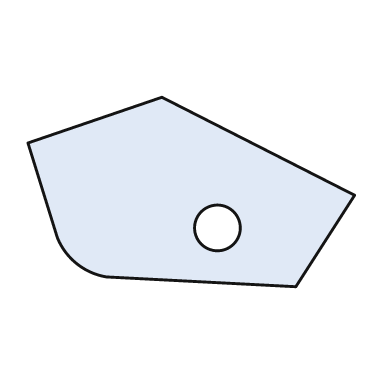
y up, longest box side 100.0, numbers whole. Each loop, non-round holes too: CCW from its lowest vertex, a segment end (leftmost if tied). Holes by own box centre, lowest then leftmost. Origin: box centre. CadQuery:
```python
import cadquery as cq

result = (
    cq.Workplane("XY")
    .moveTo(32.0, -29.0)
    .lineTo(50.0, -1.0)
    .lineTo(-9.0, 29.0)
    .lineTo(-50.0, 15.0)
    .lineTo(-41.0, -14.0)
    .threePointArc((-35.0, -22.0), (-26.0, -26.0))
    .close()
    .moveTo(8.0, -11.0)
    .circle(7.0)
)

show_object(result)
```